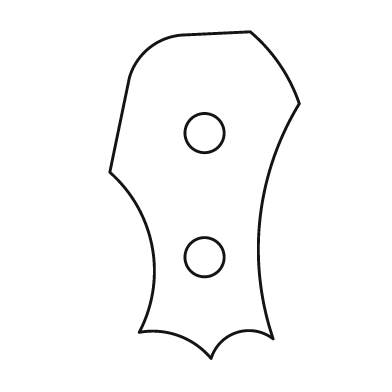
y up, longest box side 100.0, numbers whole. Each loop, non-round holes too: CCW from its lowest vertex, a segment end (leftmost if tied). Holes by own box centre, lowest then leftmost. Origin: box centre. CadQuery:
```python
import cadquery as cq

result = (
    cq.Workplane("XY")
    .moveTo(2.0, -50.0)
    .threePointArc((10.0, -42.0), (21.0, -44.0))
    .threePointArc((17.0, -7.0), (29.0, 28.0))
    .threePointArc((23.0, 40.0), (14.0, 50.0))
    .lineTo(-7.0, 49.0)
    .threePointArc((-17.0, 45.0), (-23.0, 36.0))
    .lineTo(-29.0, 7.0)
    .threePointArc((-16.0, -16.0), (-20.0, -42.0))
    .threePointArc((-8.0, -43.0), (2.0, -50.0))
    .close()
    .moveTo(0.0, -19.0)
    .circle(6.0)
    .moveTo(0.0, 19.0)
    .circle(6.0)
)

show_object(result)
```